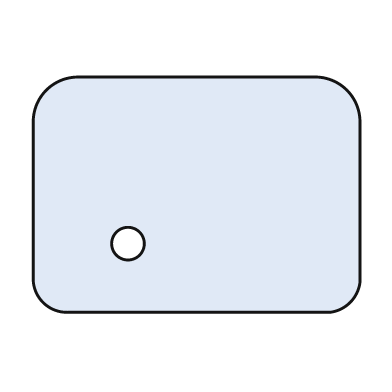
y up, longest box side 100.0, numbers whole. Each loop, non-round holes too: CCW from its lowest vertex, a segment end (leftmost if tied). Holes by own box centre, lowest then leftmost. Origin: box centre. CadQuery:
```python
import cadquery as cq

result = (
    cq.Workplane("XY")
    .moveTo(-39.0, -36.0)
    .lineTo(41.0, -36.0)
    .threePointArc((47.0, -33.0), (50.0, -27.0))
    .lineTo(50.0, 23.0)
    .threePointArc((46.0, 32.0), (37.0, 36.0))
    .lineTo(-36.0, 36.0)
    .threePointArc((-46.0, 32.0), (-50.0, 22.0))
    .lineTo(-50.0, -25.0)
    .threePointArc((-47.0, -33.0), (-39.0, -36.0))
    .close()
    .moveTo(-21.0, -15.0)
    .circle(5.0)
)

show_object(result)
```